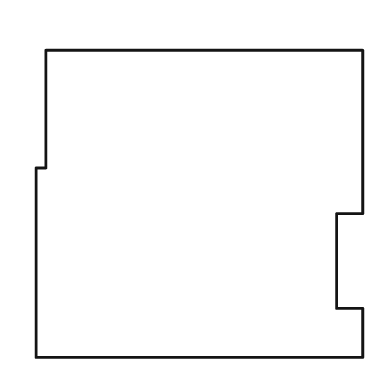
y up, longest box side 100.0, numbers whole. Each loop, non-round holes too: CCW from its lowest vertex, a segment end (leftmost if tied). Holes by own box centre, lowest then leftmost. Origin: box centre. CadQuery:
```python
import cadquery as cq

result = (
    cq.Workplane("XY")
    .moveTo(-50.0, -47.0)
    .lineTo(50.0, -47.0)
    .lineTo(50.0, -32.0)
    .lineTo(42.0, -32.0)
    .lineTo(42.0, -3.0)
    .lineTo(50.0, -3.0)
    .lineTo(50.0, 47.0)
    .lineTo(-47.0, 47.0)
    .lineTo(-47.0, 11.0)
    .lineTo(-50.0, 11.0)
    .close()
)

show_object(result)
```